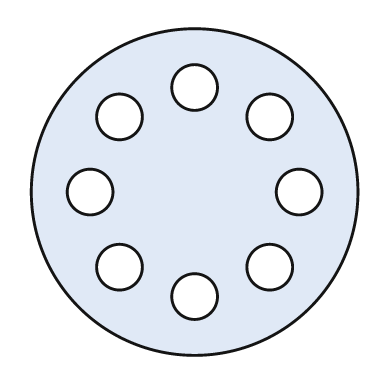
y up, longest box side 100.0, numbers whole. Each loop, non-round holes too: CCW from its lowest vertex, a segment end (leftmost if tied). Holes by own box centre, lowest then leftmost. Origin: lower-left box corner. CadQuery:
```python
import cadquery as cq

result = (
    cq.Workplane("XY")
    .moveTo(50.0, 50.0)
    .circle(50.0)
    .moveTo(50.0, 18.0)
    .circle(7.0)
    .moveTo(27.0, 27.0)
    .circle(7.0)
    .moveTo(73.0, 27.0)
    .circle(7.0)
    .moveTo(18.0, 50.0)
    .circle(7.0)
    .moveTo(82.0, 50.0)
    .circle(7.0)
    .moveTo(27.0, 73.0)
    .circle(7.0)
    .moveTo(73.0, 73.0)
    .circle(7.0)
    .moveTo(50.0, 82.0)
    .circle(7.0)
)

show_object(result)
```